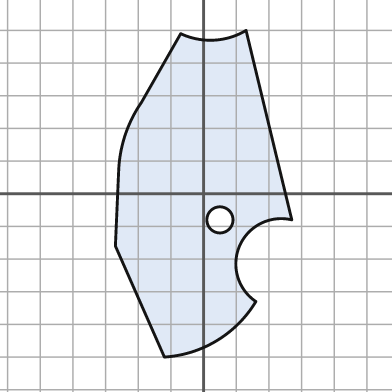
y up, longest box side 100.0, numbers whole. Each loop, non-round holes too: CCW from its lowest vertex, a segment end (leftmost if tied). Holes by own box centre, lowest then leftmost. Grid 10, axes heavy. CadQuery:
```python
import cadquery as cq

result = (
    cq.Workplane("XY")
    .moveTo(-12.0, -50.0)
    .threePointArc((4.0, -45.0), (16.0, -33.0))
    .threePointArc((11.0, -16.0), (27.0, -8.0))
    .lineTo(13.0, 50.0)
    .threePointArc((3.0, 47.0), (-7.0, 49.0))
    .lineTo(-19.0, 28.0)
    .threePointArc((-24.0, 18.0), (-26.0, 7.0))
    .lineTo(-27.0, -16.0)
    .close()
    .moveTo(5.0, -8.0)
    .circle(4.0)
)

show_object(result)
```